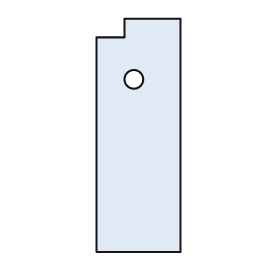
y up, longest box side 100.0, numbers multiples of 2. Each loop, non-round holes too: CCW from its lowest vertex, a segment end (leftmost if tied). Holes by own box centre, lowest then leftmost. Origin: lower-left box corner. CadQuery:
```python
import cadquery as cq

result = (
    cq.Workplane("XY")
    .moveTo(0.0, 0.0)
    .lineTo(36.0, 0.0)
    .lineTo(36.0, 100.0)
    .lineTo(12.0, 100.0)
    .lineTo(12.0, 92.0)
    .lineTo(0.0, 92.0)
    .close()
    .moveTo(16.0, 74.0)
    .circle(4.0)
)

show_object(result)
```